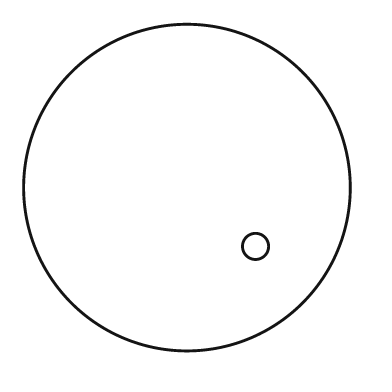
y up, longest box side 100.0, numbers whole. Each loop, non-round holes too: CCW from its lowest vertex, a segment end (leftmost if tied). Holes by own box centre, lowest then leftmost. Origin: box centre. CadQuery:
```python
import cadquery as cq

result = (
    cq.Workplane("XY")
    .moveTo(0.0, 0.0)
    .circle(50.0)
    .moveTo(21.0, -18.0)
    .circle(4.0)
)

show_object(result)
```